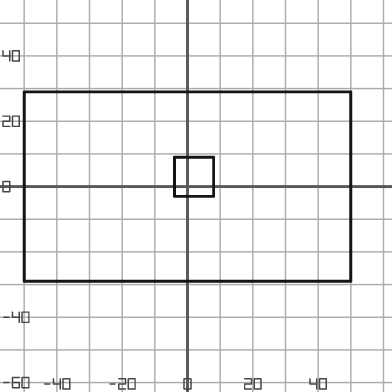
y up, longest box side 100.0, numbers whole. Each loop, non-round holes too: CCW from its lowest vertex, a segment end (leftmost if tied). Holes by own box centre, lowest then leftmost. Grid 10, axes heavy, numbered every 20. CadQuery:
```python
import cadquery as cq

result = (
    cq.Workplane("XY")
    .moveTo(-50.0, -29.0)
    .lineTo(50.0, -29.0)
    .lineTo(50.0, 29.0)
    .lineTo(-50.0, 29.0)
    .close()
    .moveTo(-4.0, -3.0)
    .lineTo(8.0, -3.0)
    .lineTo(8.0, 9.0)
    .lineTo(-4.0, 9.0)
    .close()
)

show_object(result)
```